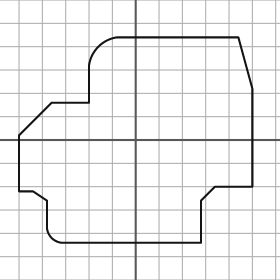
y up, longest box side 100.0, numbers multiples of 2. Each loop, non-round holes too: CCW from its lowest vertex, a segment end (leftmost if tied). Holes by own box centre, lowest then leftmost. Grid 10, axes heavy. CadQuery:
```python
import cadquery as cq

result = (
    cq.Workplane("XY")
    .moveTo(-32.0, -44.0)
    .lineTo(28.0, -44.0)
    .lineTo(28.0, -26.0)
    .lineTo(34.0, -20.0)
    .lineTo(50.0, -20.0)
    .lineTo(50.0, 22.0)
    .lineTo(44.0, 44.0)
    .lineTo(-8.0, 44.0)
    .threePointArc((-16.0, 40.0), (-20.0, 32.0))
    .lineTo(-20.0, 16.0)
    .lineTo(-36.0, 16.0)
    .lineTo(-50.0, 2.0)
    .lineTo(-50.0, -22.0)
    .lineTo(-44.0, -22.0)
    .lineTo(-38.0, -26.0)
    .lineTo(-38.0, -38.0)
    .threePointArc((-36.0, -42.0), (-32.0, -44.0))
    .close()
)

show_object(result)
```